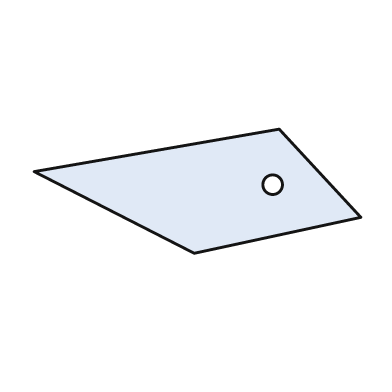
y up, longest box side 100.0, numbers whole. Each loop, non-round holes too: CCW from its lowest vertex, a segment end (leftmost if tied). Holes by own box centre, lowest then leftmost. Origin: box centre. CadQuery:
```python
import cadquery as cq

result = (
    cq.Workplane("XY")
    .moveTo(-1.0, -19.0)
    .lineTo(50.0, -8.0)
    .lineTo(25.0, 19.0)
    .lineTo(-50.0, 6.0)
    .close()
    .moveTo(23.0, 2.0)
    .circle(3.0)
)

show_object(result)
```